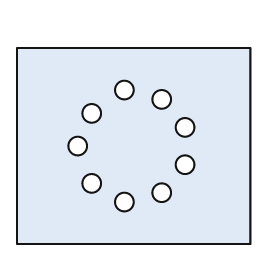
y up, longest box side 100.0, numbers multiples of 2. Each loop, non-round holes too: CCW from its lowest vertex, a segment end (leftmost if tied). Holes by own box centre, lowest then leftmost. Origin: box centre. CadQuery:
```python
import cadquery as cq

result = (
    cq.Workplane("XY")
    .moveTo(-50.0, -42.0)
    .lineTo(50.0, -42.0)
    .lineTo(50.0, 42.0)
    .lineTo(-50.0, 42.0)
    .close()
    .moveTo(-4.0, -24.0)
    .circle(4.0)
    .moveTo(12.0, -20.0)
    .circle(4.0)
    .moveTo(-18.0, -16.0)
    .circle(4.0)
    .moveTo(22.0, -8.0)
    .circle(4.0)
    .moveTo(-24.0, 0.0)
    .circle(4.0)
    .moveTo(22.0, 8.0)
    .circle(4.0)
    .moveTo(-18.0, 14.0)
    .circle(4.0)
    .moveTo(12.0, 20.0)
    .circle(4.0)
    .moveTo(-4.0, 24.0)
    .circle(4.0)
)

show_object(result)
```